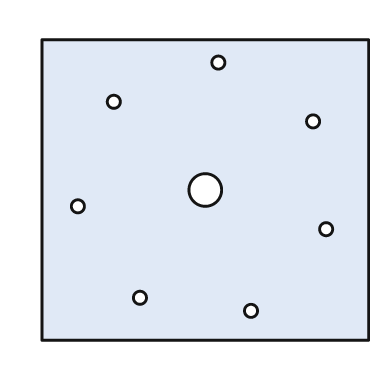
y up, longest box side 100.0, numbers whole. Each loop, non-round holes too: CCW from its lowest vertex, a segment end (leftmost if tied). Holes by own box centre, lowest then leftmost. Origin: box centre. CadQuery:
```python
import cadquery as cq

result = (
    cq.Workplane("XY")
    .moveTo(-50.0, -46.0)
    .lineTo(50.0, -46.0)
    .lineTo(50.0, 46.0)
    .lineTo(-50.0, 46.0)
    .close()
    .moveTo(14.0, -37.0)
    .circle(2.0)
    .moveTo(-20.0, -33.0)
    .circle(2.0)
    .moveTo(37.0, -12.0)
    .circle(2.0)
    .moveTo(-39.0, -5.0)
    .circle(2.0)
    .moveTo(0.0, 0.0)
    .circle(5.0)
    .moveTo(33.0, 21.0)
    .circle(2.0)
    .moveTo(-28.0, 27.0)
    .circle(2.0)
    .moveTo(4.0, 39.0)
    .circle(2.0)
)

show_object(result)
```